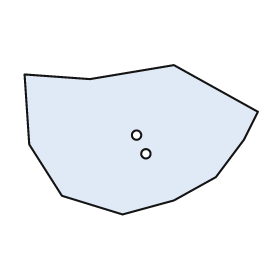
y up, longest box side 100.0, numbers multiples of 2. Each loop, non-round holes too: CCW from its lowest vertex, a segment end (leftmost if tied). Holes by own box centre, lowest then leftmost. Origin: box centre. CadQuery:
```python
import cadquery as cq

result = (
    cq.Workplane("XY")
    .moveTo(-8.0, -32.0)
    .lineTo(14.0, -26.0)
    .lineTo(32.0, -16.0)
    .lineTo(44.0, 0.0)
    .lineTo(50.0, 12.0)
    .lineTo(14.0, 32.0)
    .lineTo(-22.0, 26.0)
    .lineTo(-50.0, 28.0)
    .lineTo(-48.0, -2.0)
    .lineTo(-34.0, -24.0)
    .close()
    .moveTo(2.0, -6.0)
    .circle(2.0)
    .moveTo(-2.0, 2.0)
    .circle(2.0)
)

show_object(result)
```